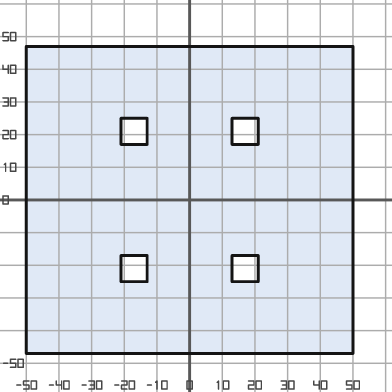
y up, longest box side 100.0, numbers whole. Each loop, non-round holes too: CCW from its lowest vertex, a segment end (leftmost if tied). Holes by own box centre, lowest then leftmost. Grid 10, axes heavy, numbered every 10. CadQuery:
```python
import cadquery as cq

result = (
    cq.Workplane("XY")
    .moveTo(-50.0, -47.0)
    .lineTo(50.0, -47.0)
    .lineTo(50.0, 47.0)
    .lineTo(-50.0, 47.0)
    .close()
    .moveTo(-21.0, -25.0)
    .lineTo(-13.0, -25.0)
    .lineTo(-13.0, -17.0)
    .lineTo(-21.0, -17.0)
    .close()
    .moveTo(13.0, -25.0)
    .lineTo(21.0, -25.0)
    .lineTo(21.0, -17.0)
    .lineTo(13.0, -17.0)
    .close()
    .moveTo(-21.0, 17.0)
    .lineTo(-13.0, 17.0)
    .lineTo(-13.0, 25.0)
    .lineTo(-21.0, 25.0)
    .close()
    .moveTo(13.0, 17.0)
    .lineTo(21.0, 17.0)
    .lineTo(21.0, 25.0)
    .lineTo(13.0, 25.0)
    .close()
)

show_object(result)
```